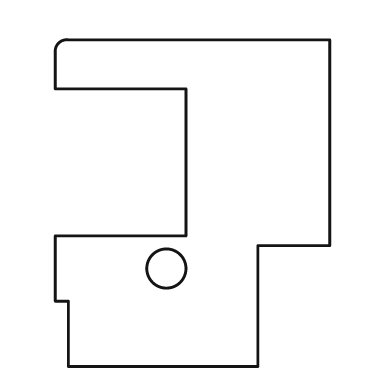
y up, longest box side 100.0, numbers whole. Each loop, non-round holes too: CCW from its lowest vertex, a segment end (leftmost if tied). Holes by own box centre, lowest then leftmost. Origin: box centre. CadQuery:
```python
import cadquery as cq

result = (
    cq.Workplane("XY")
    .moveTo(-38.0, -50.0)
    .lineTo(20.0, -50.0)
    .lineTo(20.0, -13.0)
    .lineTo(42.0, -13.0)
    .lineTo(42.0, 50.0)
    .lineTo(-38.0, 50.0)
    .threePointArc((-41.0, 49.0), (-42.0, 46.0))
    .lineTo(-42.0, 35.0)
    .lineTo(-2.0, 35.0)
    .lineTo(-2.0, -10.0)
    .lineTo(-42.0, -10.0)
    .lineTo(-42.0, -30.0)
    .lineTo(-38.0, -30.0)
    .close()
    .moveTo(-8.0, -20.0)
    .circle(6.0)
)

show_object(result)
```